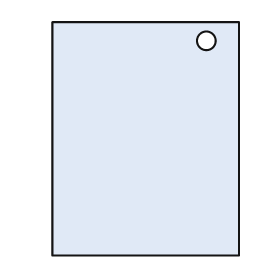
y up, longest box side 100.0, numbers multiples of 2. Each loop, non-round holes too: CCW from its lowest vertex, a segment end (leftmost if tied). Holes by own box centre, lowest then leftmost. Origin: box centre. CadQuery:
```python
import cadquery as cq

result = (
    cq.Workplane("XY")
    .moveTo(-40.0, -50.0)
    .lineTo(40.0, -50.0)
    .lineTo(40.0, 50.0)
    .lineTo(-40.0, 50.0)
    .close()
    .moveTo(26.0, 42.0)
    .circle(4.0)
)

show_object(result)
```